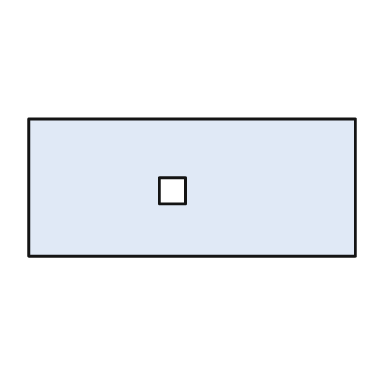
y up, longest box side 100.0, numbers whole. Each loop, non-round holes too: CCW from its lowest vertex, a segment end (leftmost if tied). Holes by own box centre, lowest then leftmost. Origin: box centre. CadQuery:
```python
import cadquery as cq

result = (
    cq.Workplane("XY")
    .moveTo(-50.0, -21.0)
    .lineTo(50.0, -21.0)
    .lineTo(50.0, 21.0)
    .lineTo(-50.0, 21.0)
    .close()
    .moveTo(-10.0, -5.0)
    .lineTo(-2.0, -5.0)
    .lineTo(-2.0, 3.0)
    .lineTo(-10.0, 3.0)
    .close()
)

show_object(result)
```